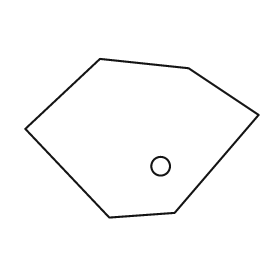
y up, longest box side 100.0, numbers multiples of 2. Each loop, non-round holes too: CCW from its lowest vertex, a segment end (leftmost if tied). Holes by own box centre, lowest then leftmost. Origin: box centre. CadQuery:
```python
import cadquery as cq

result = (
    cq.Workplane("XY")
    .moveTo(-14.0, -34.0)
    .lineTo(14.0, -32.0)
    .lineTo(50.0, 10.0)
    .lineTo(20.0, 30.0)
    .lineTo(-18.0, 34.0)
    .lineTo(-50.0, 4.0)
    .close()
    .moveTo(8.0, -12.0)
    .circle(4.0)
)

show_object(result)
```